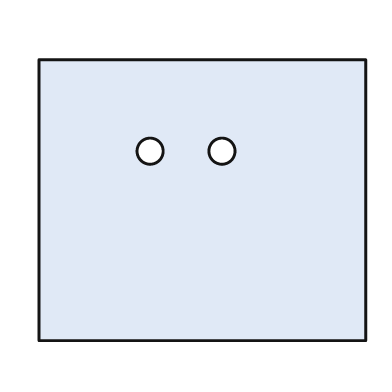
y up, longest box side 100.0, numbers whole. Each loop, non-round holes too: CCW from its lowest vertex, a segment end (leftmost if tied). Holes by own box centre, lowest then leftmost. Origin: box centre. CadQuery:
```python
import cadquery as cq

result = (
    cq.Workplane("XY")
    .moveTo(-50.0, -43.0)
    .lineTo(50.0, -43.0)
    .lineTo(50.0, 43.0)
    .lineTo(-50.0, 43.0)
    .close()
    .moveTo(-16.0, 15.0)
    .circle(4.0)
    .moveTo(6.0, 15.0)
    .circle(4.0)
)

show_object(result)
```